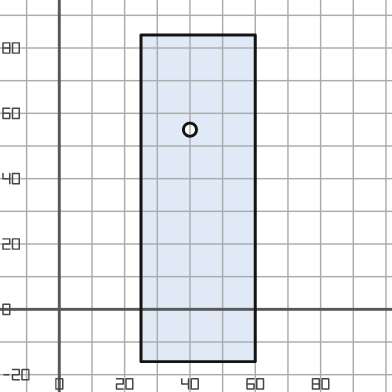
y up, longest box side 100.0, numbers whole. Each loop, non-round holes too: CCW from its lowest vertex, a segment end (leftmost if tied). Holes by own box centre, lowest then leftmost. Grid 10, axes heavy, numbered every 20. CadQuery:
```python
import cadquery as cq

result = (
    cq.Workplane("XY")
    .moveTo(25.0, -16.0)
    .lineTo(60.0, -16.0)
    .lineTo(60.0, 84.0)
    .lineTo(25.0, 84.0)
    .close()
    .moveTo(40.0, 55.0)
    .circle(2.0)
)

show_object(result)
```